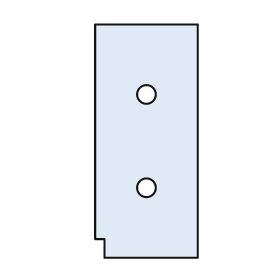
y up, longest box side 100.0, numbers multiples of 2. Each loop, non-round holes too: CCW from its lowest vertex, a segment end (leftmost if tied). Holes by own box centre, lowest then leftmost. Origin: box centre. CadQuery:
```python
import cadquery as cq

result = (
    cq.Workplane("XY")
    .moveTo(-18.0, -50.0)
    .lineTo(22.0, -50.0)
    .lineTo(22.0, 50.0)
    .lineTo(-22.0, 50.0)
    .lineTo(-22.0, -42.0)
    .lineTo(-18.0, -42.0)
    .close()
    .moveTo(0.0, -20.0)
    .circle(4.0)
    .moveTo(0.0, 20.0)
    .circle(4.0)
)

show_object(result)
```